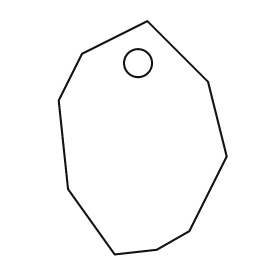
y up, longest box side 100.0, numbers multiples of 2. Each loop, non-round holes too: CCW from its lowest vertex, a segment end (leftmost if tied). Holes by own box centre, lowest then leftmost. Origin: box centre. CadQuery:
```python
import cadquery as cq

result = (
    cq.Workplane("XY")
    .moveTo(-12.0, -50.0)
    .lineTo(6.0, -48.0)
    .lineTo(20.0, -40.0)
    .lineTo(36.0, -8.0)
    .lineTo(28.0, 24.0)
    .lineTo(2.0, 50.0)
    .lineTo(-26.0, 36.0)
    .lineTo(-36.0, 16.0)
    .lineTo(-32.0, -22.0)
    .close()
    .moveTo(-2.0, 32.0)
    .circle(6.0)
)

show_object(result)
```